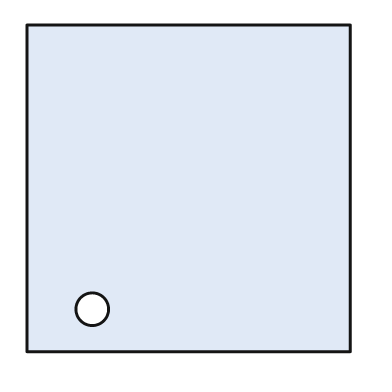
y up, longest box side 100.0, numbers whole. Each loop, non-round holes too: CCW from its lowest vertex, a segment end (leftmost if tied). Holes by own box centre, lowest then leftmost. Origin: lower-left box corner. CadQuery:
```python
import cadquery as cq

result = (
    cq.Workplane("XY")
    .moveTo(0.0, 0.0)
    .lineTo(99.0, 0.0)
    .lineTo(99.0, 100.0)
    .lineTo(0.0, 100.0)
    .close()
    .moveTo(20.0, 13.0)
    .circle(5.0)
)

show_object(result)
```